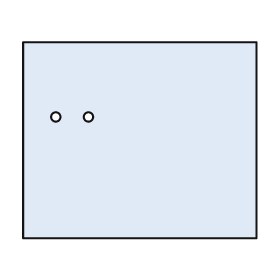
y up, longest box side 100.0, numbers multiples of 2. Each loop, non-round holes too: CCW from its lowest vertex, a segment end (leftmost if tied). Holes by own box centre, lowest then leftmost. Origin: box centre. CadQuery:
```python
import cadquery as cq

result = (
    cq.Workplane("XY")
    .moveTo(-50.0, -42.0)
    .lineTo(50.0, -42.0)
    .lineTo(50.0, 42.0)
    .lineTo(-50.0, 42.0)
    .close()
    .moveTo(-36.0, 10.0)
    .circle(2.0)
    .moveTo(-22.0, 10.0)
    .circle(2.0)
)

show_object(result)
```